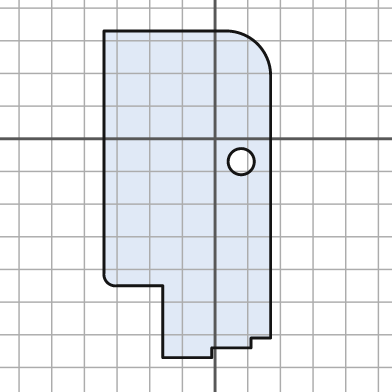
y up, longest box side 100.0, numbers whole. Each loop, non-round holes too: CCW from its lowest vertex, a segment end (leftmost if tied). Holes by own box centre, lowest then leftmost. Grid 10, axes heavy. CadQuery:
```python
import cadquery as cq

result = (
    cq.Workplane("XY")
    .moveTo(-16.0, -67.0)
    .lineTo(-1.0, -67.0)
    .lineTo(-1.0, -64.0)
    .lineTo(11.0, -64.0)
    .lineTo(11.0, -61.0)
    .lineTo(17.0, -61.0)
    .lineTo(17.0, 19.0)
    .threePointArc((13.0, 29.0), (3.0, 33.0))
    .lineTo(-34.0, 33.0)
    .lineTo(-34.0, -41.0)
    .threePointArc((-33.0, -44.0), (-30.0, -45.0))
    .lineTo(-16.0, -45.0)
    .close()
    .moveTo(8.0, -7.0)
    .circle(4.0)
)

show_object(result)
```